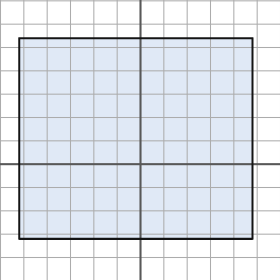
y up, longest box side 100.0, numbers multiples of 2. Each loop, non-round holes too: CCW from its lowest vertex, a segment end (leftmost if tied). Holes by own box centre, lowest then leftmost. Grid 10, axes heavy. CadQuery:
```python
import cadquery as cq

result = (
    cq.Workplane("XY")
    .moveTo(-52.0, -32.0)
    .lineTo(48.0, -32.0)
    .lineTo(48.0, 54.0)
    .lineTo(-52.0, 54.0)
    .close()
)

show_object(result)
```